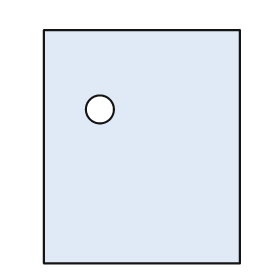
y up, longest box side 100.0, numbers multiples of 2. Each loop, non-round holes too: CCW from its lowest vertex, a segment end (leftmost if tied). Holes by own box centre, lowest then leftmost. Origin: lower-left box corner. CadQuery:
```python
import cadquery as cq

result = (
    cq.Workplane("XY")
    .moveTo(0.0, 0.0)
    .lineTo(84.0, 0.0)
    .lineTo(84.0, 100.0)
    .lineTo(0.0, 100.0)
    .close()
    .moveTo(24.0, 66.0)
    .circle(6.0)
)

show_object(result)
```